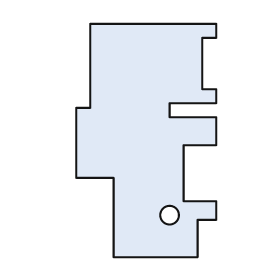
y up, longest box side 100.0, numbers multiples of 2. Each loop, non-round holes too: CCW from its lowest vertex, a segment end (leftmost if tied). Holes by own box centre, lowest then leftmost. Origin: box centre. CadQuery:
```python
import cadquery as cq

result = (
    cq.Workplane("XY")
    .moveTo(-14.0, -50.0)
    .lineTo(22.0, -50.0)
    .lineTo(22.0, -34.0)
    .lineTo(30.0, -34.0)
    .lineTo(30.0, -26.0)
    .lineTo(16.0, -26.0)
    .lineTo(16.0, -2.0)
    .lineTo(30.0, -2.0)
    .lineTo(30.0, 10.0)
    .lineTo(10.0, 10.0)
    .lineTo(10.0, 16.0)
    .lineTo(30.0, 16.0)
    .lineTo(30.0, 22.0)
    .lineTo(24.0, 22.0)
    .lineTo(24.0, 44.0)
    .lineTo(30.0, 44.0)
    .lineTo(30.0, 50.0)
    .lineTo(-24.0, 50.0)
    .lineTo(-24.0, 14.0)
    .lineTo(-30.0, 14.0)
    .lineTo(-30.0, -16.0)
    .lineTo(-14.0, -16.0)
    .close()
    .moveTo(10.0, -32.0)
    .circle(4.0)
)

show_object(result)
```